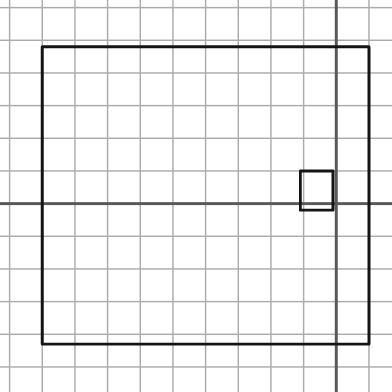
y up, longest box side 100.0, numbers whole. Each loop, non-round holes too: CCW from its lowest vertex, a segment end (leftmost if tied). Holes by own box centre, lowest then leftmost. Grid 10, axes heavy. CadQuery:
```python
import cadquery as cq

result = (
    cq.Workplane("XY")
    .moveTo(-90.0, -43.0)
    .lineTo(10.0, -43.0)
    .lineTo(10.0, 48.0)
    .lineTo(-90.0, 48.0)
    .close()
    .moveTo(-11.0, -2.0)
    .lineTo(-1.0, -2.0)
    .lineTo(-1.0, 10.0)
    .lineTo(-11.0, 10.0)
    .close()
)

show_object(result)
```